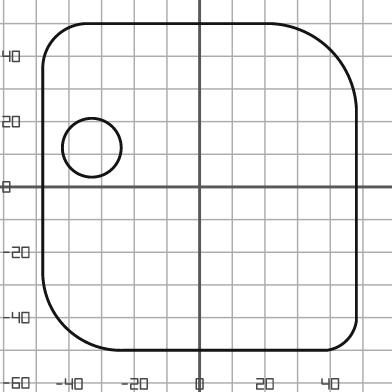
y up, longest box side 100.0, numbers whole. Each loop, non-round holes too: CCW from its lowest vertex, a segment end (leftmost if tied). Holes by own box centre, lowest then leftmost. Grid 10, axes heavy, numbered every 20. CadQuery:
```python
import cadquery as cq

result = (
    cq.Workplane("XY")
    .moveTo(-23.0, -50.0)
    .lineTo(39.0, -50.0)
    .threePointArc((45.0, -47.0), (48.0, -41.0))
    .lineTo(48.0, 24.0)
    .threePointArc((40.0, 42.0), (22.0, 50.0))
    .lineTo(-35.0, 50.0)
    .threePointArc((-44.0, 46.0), (-48.0, 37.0))
    .lineTo(-48.0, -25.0)
    .threePointArc((-41.0, -43.0), (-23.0, -50.0))
    .close()
    .moveTo(-33.0, 12.0)
    .circle(9.0)
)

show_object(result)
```